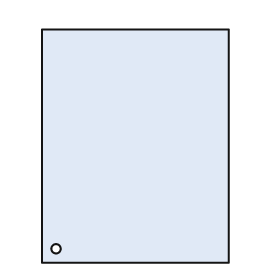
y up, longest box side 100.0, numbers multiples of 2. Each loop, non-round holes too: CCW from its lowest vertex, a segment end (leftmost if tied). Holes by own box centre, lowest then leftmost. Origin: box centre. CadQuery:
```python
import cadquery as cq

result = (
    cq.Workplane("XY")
    .moveTo(-40.0, -50.0)
    .lineTo(40.0, -50.0)
    .lineTo(40.0, 50.0)
    .lineTo(-40.0, 50.0)
    .close()
    .moveTo(-34.0, -44.0)
    .circle(2.0)
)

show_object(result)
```